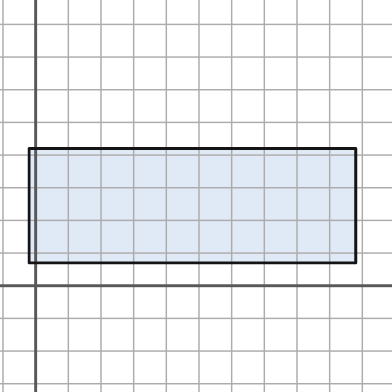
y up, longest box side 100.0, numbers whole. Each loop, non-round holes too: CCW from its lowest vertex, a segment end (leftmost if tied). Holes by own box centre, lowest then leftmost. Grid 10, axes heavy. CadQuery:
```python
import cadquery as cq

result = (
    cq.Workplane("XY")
    .moveTo(-2.0, 7.0)
    .lineTo(98.0, 7.0)
    .lineTo(98.0, 42.0)
    .lineTo(-2.0, 42.0)
    .close()
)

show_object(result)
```